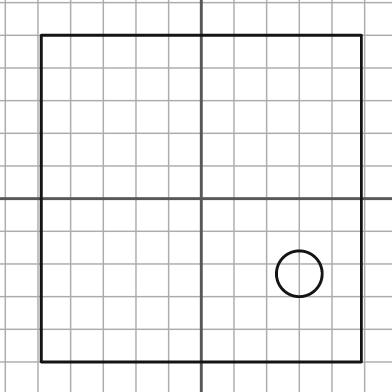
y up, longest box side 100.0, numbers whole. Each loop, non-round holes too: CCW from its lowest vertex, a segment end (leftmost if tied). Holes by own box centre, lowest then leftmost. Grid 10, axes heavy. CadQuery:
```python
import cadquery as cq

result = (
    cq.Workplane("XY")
    .moveTo(-49.0, -50.0)
    .lineTo(49.0, -50.0)
    .lineTo(49.0, 50.0)
    .lineTo(-49.0, 50.0)
    .close()
    .moveTo(30.0, -23.0)
    .circle(7.0)
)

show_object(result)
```